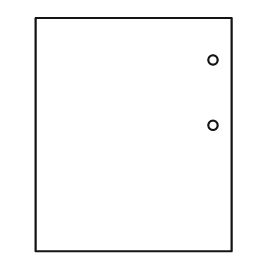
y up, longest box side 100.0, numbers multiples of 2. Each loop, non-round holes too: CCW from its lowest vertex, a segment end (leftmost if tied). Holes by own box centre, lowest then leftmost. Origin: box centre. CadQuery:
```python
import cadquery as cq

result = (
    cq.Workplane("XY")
    .moveTo(-42.0, -50.0)
    .lineTo(42.0, -50.0)
    .lineTo(42.0, 50.0)
    .lineTo(-42.0, 50.0)
    .close()
    .moveTo(34.0, 4.0)
    .circle(2.0)
    .moveTo(34.0, 32.0)
    .circle(2.0)
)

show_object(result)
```